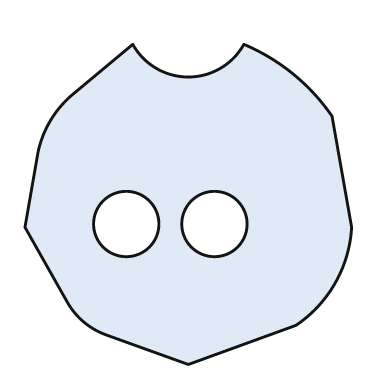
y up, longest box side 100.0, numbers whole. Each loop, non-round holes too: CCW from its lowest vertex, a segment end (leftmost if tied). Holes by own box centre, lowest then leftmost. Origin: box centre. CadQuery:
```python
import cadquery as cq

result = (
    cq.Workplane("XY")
    .moveTo(0.0, -49.0)
    .lineTo(33.0, -37.0)
    .threePointArc((45.0, -24.0), (50.0, -7.0))
    .lineTo(44.0, 27.0)
    .threePointArc((32.0, 40.0), (17.0, 49.0))
    .threePointArc((0.0, 39.0), (-17.0, 49.0))
    .lineTo(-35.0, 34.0)
    .threePointArc((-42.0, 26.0), (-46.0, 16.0))
    .lineTo(-50.0, -7.0)
    .lineTo(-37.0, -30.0)
    .threePointArc((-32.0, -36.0), (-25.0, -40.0))
    .close()
    .moveTo(-19.0, -6.0)
    .circle(10.0)
    .moveTo(8.0, -6.0)
    .circle(10.0)
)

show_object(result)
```